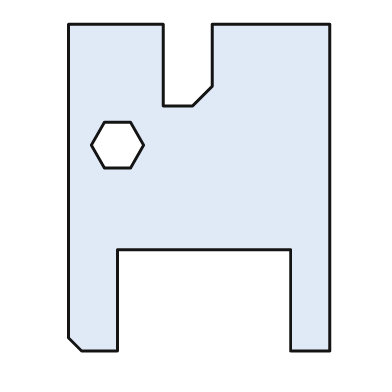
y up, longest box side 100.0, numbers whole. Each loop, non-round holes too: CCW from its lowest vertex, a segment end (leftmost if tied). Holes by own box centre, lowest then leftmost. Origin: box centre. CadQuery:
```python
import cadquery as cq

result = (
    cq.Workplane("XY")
    .moveTo(-36.0, -50.0)
    .lineTo(-25.0, -50.0)
    .lineTo(-25.0, -19.0)
    .lineTo(28.0, -19.0)
    .lineTo(28.0, -50.0)
    .lineTo(40.0, -50.0)
    .lineTo(40.0, 50.0)
    .lineTo(4.0, 50.0)
    .lineTo(4.0, 31.0)
    .lineTo(-2.0, 25.0)
    .lineTo(-11.0, 25.0)
    .lineTo(-11.0, 50.0)
    .lineTo(-40.0, 50.0)
    .lineTo(-40.0, -46.0)
    .close()
    .moveTo(-29.0, 6.0)
    .lineTo(-21.0, 6.0)
    .lineTo(-17.0, 13.0)
    .lineTo(-21.0, 20.0)
    .lineTo(-29.0, 20.0)
    .lineTo(-33.0, 13.0)
    .close()
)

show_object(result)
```